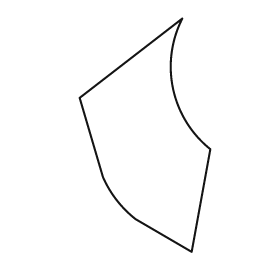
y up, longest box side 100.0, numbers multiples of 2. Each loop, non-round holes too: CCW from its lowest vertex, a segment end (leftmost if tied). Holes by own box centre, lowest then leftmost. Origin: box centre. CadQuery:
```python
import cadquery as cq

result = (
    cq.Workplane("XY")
    .moveTo(20.0, -50.0)
    .lineTo(28.0, -6.0)
    .threePointArc((12.0, 20.0), (16.0, 50.0))
    .lineTo(-28.0, 16.0)
    .lineTo(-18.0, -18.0)
    .threePointArc((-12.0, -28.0), (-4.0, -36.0))
    .close()
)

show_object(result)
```